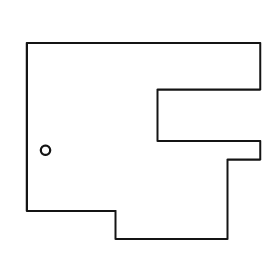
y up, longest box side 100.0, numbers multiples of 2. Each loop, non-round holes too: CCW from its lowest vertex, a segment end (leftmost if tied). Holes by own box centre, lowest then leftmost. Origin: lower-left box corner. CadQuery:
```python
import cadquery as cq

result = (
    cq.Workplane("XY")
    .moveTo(38.0, 0.0)
    .lineTo(86.0, 0.0)
    .lineTo(86.0, 34.0)
    .lineTo(100.0, 34.0)
    .lineTo(100.0, 42.0)
    .lineTo(56.0, 42.0)
    .lineTo(56.0, 64.0)
    .lineTo(100.0, 64.0)
    .lineTo(100.0, 84.0)
    .lineTo(0.0, 84.0)
    .lineTo(0.0, 12.0)
    .lineTo(38.0, 12.0)
    .close()
    .moveTo(8.0, 38.0)
    .circle(2.0)
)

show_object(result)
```